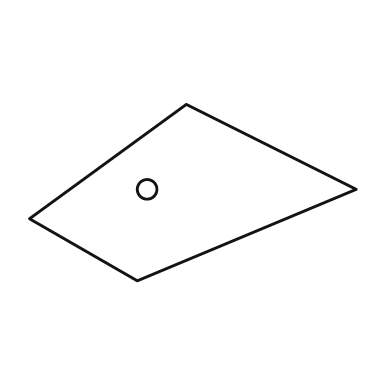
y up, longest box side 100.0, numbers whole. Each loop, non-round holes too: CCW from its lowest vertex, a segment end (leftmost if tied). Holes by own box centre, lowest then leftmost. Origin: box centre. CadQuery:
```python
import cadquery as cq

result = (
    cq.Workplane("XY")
    .moveTo(-17.0, -27.0)
    .lineTo(50.0, 1.0)
    .lineTo(-2.0, 27.0)
    .lineTo(-50.0, -8.0)
    .close()
    .moveTo(-14.0, 1.0)
    .circle(3.0)
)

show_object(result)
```